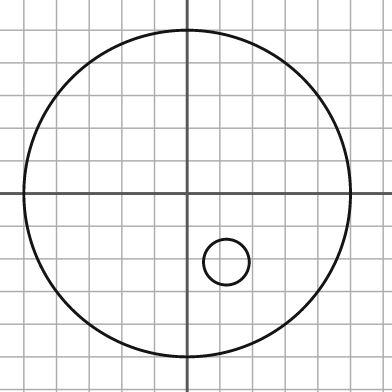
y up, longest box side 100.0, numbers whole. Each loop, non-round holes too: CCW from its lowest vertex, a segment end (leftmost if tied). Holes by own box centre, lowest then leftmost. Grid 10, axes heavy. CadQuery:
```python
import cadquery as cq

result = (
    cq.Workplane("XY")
    .moveTo(0.0, 0.0)
    .circle(50.0)
    .moveTo(12.0, -21.0)
    .circle(7.0)
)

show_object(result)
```